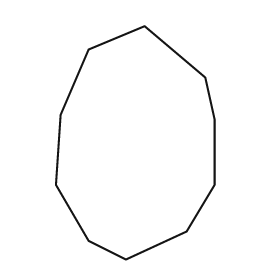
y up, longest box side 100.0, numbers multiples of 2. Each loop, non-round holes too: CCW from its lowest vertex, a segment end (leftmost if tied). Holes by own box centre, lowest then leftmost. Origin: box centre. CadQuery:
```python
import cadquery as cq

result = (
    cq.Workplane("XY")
    .moveTo(-4.0, -50.0)
    .lineTo(22.0, -38.0)
    .lineTo(34.0, -18.0)
    .lineTo(34.0, 10.0)
    .lineTo(30.0, 28.0)
    .lineTo(4.0, 50.0)
    .lineTo(-20.0, 40.0)
    .lineTo(-32.0, 12.0)
    .lineTo(-34.0, -18.0)
    .lineTo(-20.0, -42.0)
    .close()
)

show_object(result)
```